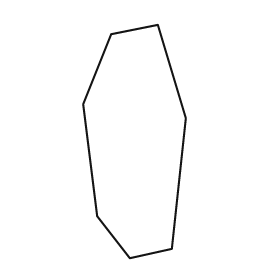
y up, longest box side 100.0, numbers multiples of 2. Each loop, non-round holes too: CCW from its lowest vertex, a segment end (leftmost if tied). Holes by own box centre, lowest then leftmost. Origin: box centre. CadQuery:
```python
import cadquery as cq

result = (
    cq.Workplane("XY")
    .moveTo(-2.0, -50.0)
    .lineTo(16.0, -46.0)
    .lineTo(22.0, 10.0)
    .lineTo(10.0, 50.0)
    .lineTo(-10.0, 46.0)
    .lineTo(-22.0, 16.0)
    .lineTo(-16.0, -32.0)
    .close()
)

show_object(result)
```